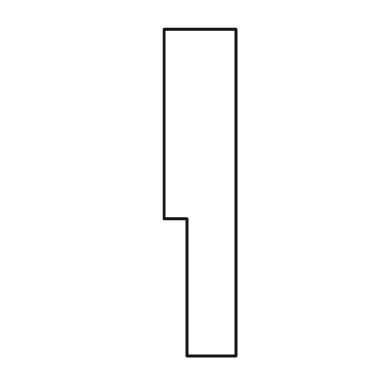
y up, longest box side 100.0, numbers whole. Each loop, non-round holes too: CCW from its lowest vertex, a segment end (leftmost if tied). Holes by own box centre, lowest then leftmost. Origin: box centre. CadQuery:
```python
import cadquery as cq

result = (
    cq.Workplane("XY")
    .moveTo(-4.0, -50.0)
    .lineTo(11.0, -50.0)
    .lineTo(11.0, 50.0)
    .lineTo(-11.0, 50.0)
    .lineTo(-11.0, -8.0)
    .lineTo(-4.0, -8.0)
    .close()
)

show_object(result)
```